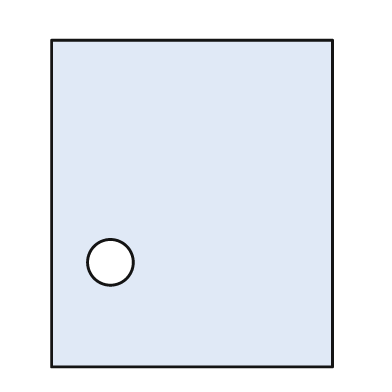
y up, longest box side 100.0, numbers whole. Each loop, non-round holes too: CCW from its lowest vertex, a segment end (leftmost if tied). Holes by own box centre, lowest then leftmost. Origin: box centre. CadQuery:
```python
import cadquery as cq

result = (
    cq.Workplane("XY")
    .moveTo(-43.0, -50.0)
    .lineTo(43.0, -50.0)
    .lineTo(43.0, 50.0)
    .lineTo(-43.0, 50.0)
    .close()
    .moveTo(-25.0, -18.0)
    .circle(7.0)
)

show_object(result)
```